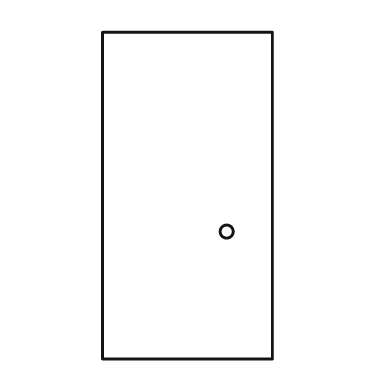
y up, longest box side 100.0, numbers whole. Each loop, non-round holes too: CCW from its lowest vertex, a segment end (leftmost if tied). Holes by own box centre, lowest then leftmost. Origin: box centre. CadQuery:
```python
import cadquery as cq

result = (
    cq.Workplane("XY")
    .moveTo(-26.0, -50.0)
    .lineTo(26.0, -50.0)
    .lineTo(26.0, 50.0)
    .lineTo(-26.0, 50.0)
    .close()
    .moveTo(12.0, -11.0)
    .circle(2.0)
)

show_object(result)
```